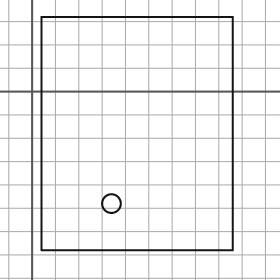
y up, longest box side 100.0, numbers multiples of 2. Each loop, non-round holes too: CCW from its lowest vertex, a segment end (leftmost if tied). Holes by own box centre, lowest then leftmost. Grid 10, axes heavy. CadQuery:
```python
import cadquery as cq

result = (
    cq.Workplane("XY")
    .moveTo(4.0, -68.0)
    .lineTo(86.0, -68.0)
    .lineTo(86.0, 32.0)
    .lineTo(4.0, 32.0)
    .close()
    .moveTo(34.0, -48.0)
    .circle(4.0)
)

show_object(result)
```